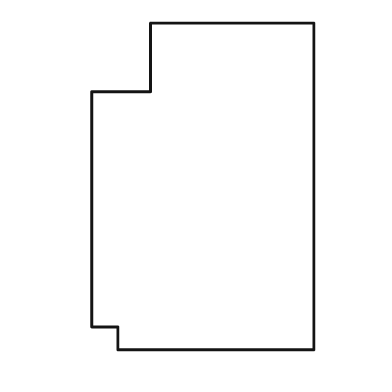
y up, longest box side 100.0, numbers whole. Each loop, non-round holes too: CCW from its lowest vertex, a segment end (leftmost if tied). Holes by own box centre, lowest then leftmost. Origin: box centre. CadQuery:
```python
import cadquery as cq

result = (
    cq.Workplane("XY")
    .moveTo(-26.0, -50.0)
    .lineTo(34.0, -50.0)
    .lineTo(34.0, 50.0)
    .lineTo(-16.0, 50.0)
    .lineTo(-16.0, 29.0)
    .lineTo(-34.0, 29.0)
    .lineTo(-34.0, -43.0)
    .lineTo(-26.0, -43.0)
    .close()
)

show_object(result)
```